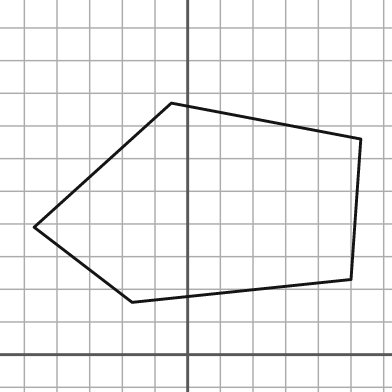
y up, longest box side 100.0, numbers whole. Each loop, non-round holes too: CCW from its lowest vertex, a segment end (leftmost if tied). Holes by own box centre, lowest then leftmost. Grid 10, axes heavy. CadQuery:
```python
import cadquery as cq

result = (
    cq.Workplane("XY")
    .moveTo(-17.0, 16.0)
    .lineTo(50.0, 23.0)
    .lineTo(53.0, 66.0)
    .lineTo(-5.0, 77.0)
    .lineTo(-47.0, 39.0)
    .close()
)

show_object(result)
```